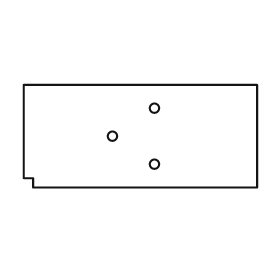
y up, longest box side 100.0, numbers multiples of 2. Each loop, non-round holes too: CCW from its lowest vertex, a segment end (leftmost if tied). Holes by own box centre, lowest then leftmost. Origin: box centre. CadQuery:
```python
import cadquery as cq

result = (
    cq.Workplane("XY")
    .moveTo(-46.0, -22.0)
    .lineTo(50.0, -22.0)
    .lineTo(50.0, 22.0)
    .lineTo(-50.0, 22.0)
    .lineTo(-50.0, -18.0)
    .lineTo(-46.0, -18.0)
    .close()
    .moveTo(6.0, -12.0)
    .circle(2.0)
    .moveTo(-12.0, 0.0)
    .circle(2.0)
    .moveTo(6.0, 12.0)
    .circle(2.0)
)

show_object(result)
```